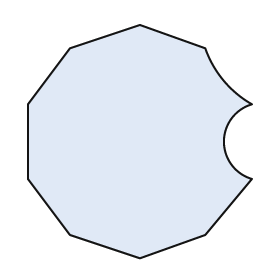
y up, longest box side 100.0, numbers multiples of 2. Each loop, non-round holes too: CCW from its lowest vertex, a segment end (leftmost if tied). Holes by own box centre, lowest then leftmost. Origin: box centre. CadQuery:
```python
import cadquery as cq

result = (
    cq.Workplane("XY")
    .moveTo(0.0, -50.0)
    .lineTo(28.0, -40.0)
    .lineTo(48.0, -16.0)
    .threePointArc((36.0, 0.0), (48.0, 16.0))
    .threePointArc((36.0, 26.0), (28.0, 40.0))
    .lineTo(0.0, 50.0)
    .lineTo(-30.0, 40.0)
    .lineTo(-48.0, 16.0)
    .lineTo(-48.0, -16.0)
    .lineTo(-30.0, -40.0)
    .close()
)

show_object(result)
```